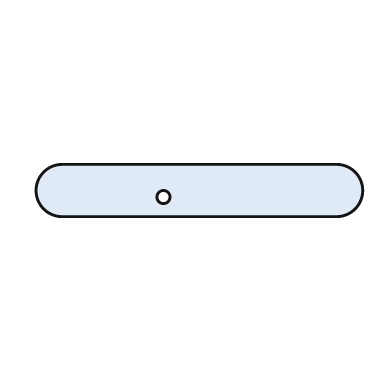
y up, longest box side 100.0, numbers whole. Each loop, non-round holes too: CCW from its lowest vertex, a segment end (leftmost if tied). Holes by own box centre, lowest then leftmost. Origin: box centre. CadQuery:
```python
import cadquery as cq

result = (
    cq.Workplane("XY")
    .moveTo(-42.0, -8.0)
    .lineTo(42.0, -8.0)
    .threePointArc((50.0, 0.0), (42.0, 8.0))
    .lineTo(-42.0, 8.0)
    .threePointArc((-50.0, 0.0), (-42.0, -8.0))
    .close()
    .moveTo(-11.0, -2.0)
    .circle(2.0)
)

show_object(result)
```